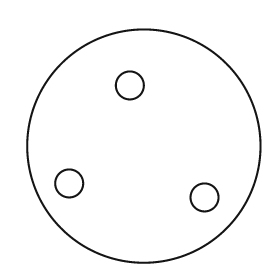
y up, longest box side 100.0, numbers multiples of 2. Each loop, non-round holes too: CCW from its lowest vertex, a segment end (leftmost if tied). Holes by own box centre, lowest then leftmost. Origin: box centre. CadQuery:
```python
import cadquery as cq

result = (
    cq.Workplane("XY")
    .moveTo(0.0, 0.0)
    .circle(50.0)
    .moveTo(26.0, -22.0)
    .circle(6.0)
    .moveTo(-32.0, -16.0)
    .circle(6.0)
    .moveTo(-6.0, 26.0)
    .circle(6.0)
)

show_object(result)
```